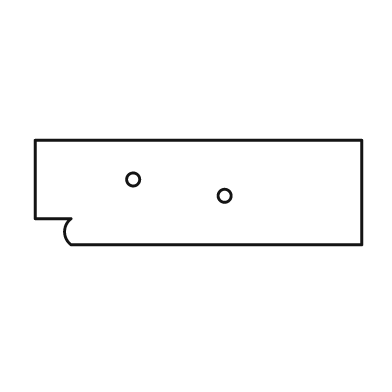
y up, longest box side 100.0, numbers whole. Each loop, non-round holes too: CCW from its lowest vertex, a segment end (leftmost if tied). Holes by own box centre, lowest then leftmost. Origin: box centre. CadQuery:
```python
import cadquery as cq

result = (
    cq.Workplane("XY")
    .moveTo(-39.0, -16.0)
    .lineTo(50.0, -16.0)
    .lineTo(50.0, 16.0)
    .lineTo(-50.0, 16.0)
    .lineTo(-50.0, -8.0)
    .lineTo(-39.0, -8.0)
    .threePointArc((-41.0, -12.0), (-39.0, -16.0))
    .close()
    .moveTo(8.0, -1.0)
    .circle(2.0)
    .moveTo(-20.0, 4.0)
    .circle(2.0)
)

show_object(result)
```